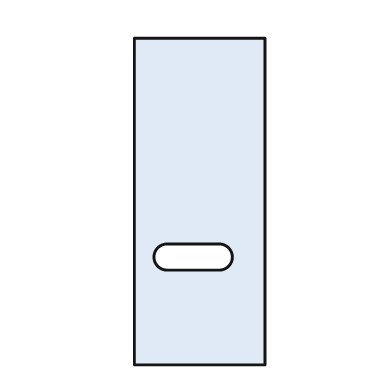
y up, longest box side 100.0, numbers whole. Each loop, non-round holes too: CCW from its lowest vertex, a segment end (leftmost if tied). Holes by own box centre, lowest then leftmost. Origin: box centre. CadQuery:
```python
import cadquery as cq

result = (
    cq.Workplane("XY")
    .moveTo(-20.0, -50.0)
    .lineTo(20.0, -50.0)
    .lineTo(20.0, 50.0)
    .lineTo(-20.0, 50.0)
    .close()
    .moveTo(-10.0, -21.0)
    .lineTo(6.0, -21.0)
    .threePointArc((10.0, -17.0), (6.0, -13.0))
    .lineTo(-10.0, -13.0)
    .threePointArc((-14.0, -17.0), (-10.0, -21.0))
    .close()
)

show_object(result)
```